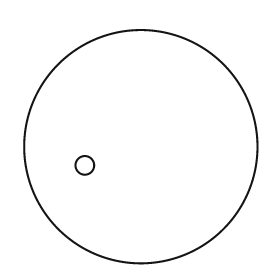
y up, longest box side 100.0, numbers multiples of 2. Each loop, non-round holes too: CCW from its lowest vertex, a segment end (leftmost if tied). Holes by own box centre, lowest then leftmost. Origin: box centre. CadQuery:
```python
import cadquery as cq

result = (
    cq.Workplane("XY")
    .moveTo(0.0, 0.0)
    .circle(50.0)
    .moveTo(-24.0, -8.0)
    .circle(4.0)
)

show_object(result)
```